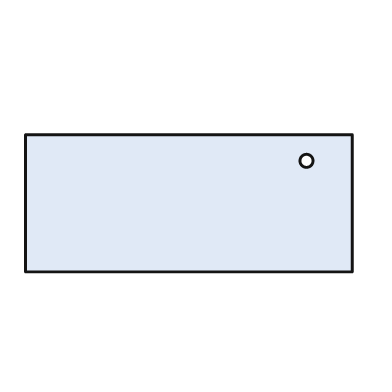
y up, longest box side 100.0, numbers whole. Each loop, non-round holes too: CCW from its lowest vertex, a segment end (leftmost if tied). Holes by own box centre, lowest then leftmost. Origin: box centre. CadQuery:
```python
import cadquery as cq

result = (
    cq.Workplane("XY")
    .moveTo(-50.0, -21.0)
    .lineTo(50.0, -21.0)
    .lineTo(50.0, 21.0)
    .lineTo(-50.0, 21.0)
    .close()
    .moveTo(36.0, 13.0)
    .circle(2.0)
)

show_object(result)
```